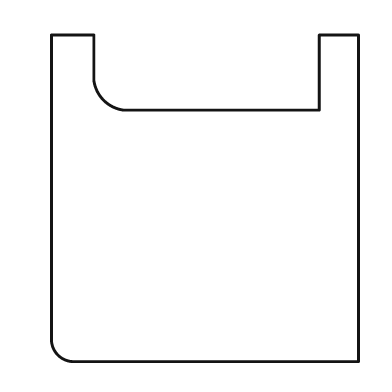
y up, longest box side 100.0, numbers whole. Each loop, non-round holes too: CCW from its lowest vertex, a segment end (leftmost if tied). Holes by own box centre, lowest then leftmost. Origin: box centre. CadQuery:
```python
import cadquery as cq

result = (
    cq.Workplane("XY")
    .moveTo(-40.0, -50.0)
    .lineTo(47.0, -50.0)
    .lineTo(47.0, 50.0)
    .lineTo(35.0, 50.0)
    .lineTo(35.0, 27.0)
    .lineTo(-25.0, 27.0)
    .threePointArc((-31.0, 30.0), (-34.0, 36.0))
    .lineTo(-34.0, 50.0)
    .lineTo(-47.0, 50.0)
    .lineTo(-47.0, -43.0)
    .threePointArc((-45.0, -48.0), (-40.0, -50.0))
    .close()
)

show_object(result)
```